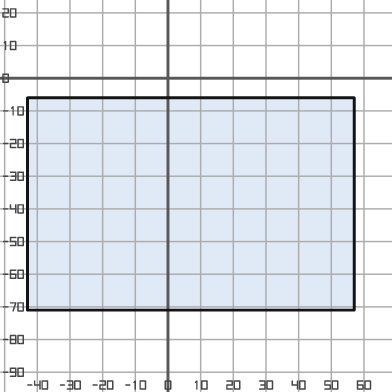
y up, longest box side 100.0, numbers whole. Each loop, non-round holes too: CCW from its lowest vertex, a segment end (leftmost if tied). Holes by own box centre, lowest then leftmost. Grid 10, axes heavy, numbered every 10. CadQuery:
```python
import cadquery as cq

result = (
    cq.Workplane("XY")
    .moveTo(-43.0, -71.0)
    .lineTo(57.0, -71.0)
    .lineTo(57.0, -6.0)
    .lineTo(-43.0, -6.0)
    .close()
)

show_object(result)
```